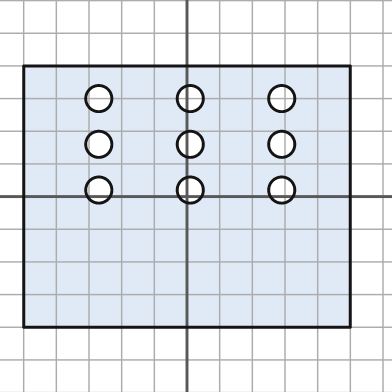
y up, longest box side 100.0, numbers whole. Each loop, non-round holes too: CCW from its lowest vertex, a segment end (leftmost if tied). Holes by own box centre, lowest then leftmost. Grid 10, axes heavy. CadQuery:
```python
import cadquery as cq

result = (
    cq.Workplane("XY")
    .moveTo(-50.0, -40.0)
    .lineTo(50.0, -40.0)
    .lineTo(50.0, 40.0)
    .lineTo(-50.0, 40.0)
    .close()
    .moveTo(-27.0, 2.0)
    .circle(4.0)
    .moveTo(1.0, 2.0)
    .circle(4.0)
    .moveTo(29.0, 2.0)
    .circle(4.0)
    .moveTo(-27.0, 16.0)
    .circle(4.0)
    .moveTo(1.0, 16.0)
    .circle(4.0)
    .moveTo(29.0, 16.0)
    .circle(4.0)
    .moveTo(-27.0, 30.0)
    .circle(4.0)
    .moveTo(1.0, 30.0)
    .circle(4.0)
    .moveTo(29.0, 30.0)
    .circle(4.0)
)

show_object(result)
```